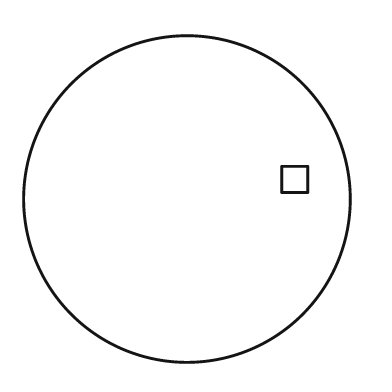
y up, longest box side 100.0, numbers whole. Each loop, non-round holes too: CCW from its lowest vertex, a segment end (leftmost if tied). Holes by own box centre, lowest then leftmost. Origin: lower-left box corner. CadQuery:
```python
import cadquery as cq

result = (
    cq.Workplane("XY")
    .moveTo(50.0, 50.0)
    .circle(50.0)
    .moveTo(79.0, 52.0)
    .lineTo(87.0, 52.0)
    .lineTo(87.0, 60.0)
    .lineTo(79.0, 60.0)
    .close()
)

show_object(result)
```